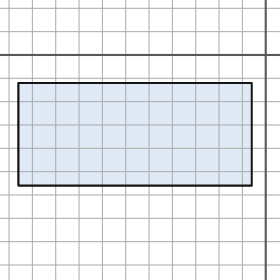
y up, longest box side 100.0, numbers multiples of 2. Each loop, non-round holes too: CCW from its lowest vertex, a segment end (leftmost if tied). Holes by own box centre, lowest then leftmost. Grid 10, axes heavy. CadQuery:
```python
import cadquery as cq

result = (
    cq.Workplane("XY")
    .moveTo(-106.0, -56.0)
    .lineTo(-6.0, -56.0)
    .lineTo(-6.0, -12.0)
    .lineTo(-106.0, -12.0)
    .close()
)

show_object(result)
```